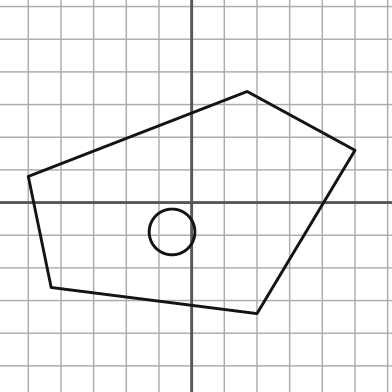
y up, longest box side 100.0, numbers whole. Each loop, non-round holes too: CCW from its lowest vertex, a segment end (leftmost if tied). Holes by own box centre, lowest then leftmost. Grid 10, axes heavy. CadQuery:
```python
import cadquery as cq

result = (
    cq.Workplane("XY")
    .moveTo(20.0, -34.0)
    .lineTo(50.0, 16.0)
    .lineTo(17.0, 34.0)
    .lineTo(-50.0, 8.0)
    .lineTo(-43.0, -26.0)
    .close()
    .moveTo(-6.0, -9.0)
    .circle(7.0)
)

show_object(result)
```